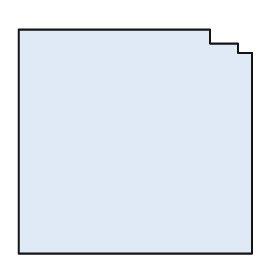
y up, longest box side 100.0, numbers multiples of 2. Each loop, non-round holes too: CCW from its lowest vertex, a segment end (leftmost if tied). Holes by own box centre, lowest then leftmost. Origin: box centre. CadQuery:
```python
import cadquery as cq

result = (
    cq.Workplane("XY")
    .moveTo(-50.0, -48.0)
    .lineTo(50.0, -48.0)
    .lineTo(50.0, 38.0)
    .lineTo(44.0, 38.0)
    .lineTo(44.0, 42.0)
    .lineTo(32.0, 42.0)
    .lineTo(32.0, 48.0)
    .lineTo(-50.0, 48.0)
    .close()
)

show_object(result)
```